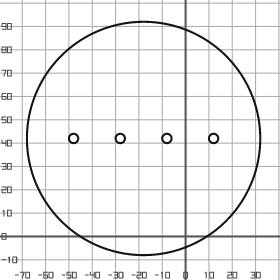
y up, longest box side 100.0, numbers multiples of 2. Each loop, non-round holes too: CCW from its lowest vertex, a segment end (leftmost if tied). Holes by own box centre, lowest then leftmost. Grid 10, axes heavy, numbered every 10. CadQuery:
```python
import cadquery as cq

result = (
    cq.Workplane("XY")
    .moveTo(-18.0, 42.0)
    .circle(50.0)
    .moveTo(-48.0, 42.0)
    .circle(2.0)
    .moveTo(-28.0, 42.0)
    .circle(2.0)
    .moveTo(-8.0, 42.0)
    .circle(2.0)
    .moveTo(12.0, 42.0)
    .circle(2.0)
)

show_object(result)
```